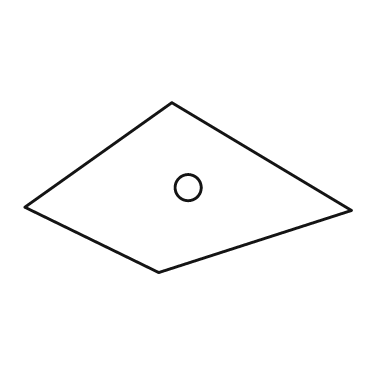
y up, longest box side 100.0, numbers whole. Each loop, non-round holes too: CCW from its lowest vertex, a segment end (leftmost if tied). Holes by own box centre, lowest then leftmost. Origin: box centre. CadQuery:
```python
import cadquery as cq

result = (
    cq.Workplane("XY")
    .moveTo(-9.0, -26.0)
    .lineTo(50.0, -7.0)
    .lineTo(-5.0, 26.0)
    .lineTo(-50.0, -6.0)
    .close()
    .moveTo(0.0, 0.0)
    .circle(4.0)
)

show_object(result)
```